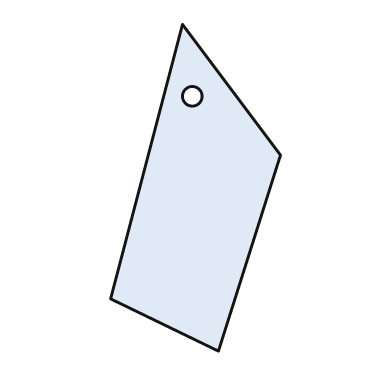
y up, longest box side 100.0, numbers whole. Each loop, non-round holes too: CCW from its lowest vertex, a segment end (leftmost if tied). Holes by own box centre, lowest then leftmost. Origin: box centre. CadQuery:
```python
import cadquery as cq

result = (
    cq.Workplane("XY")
    .moveTo(7.0, -50.0)
    .lineTo(26.0, 10.0)
    .lineTo(-4.0, 50.0)
    .lineTo(-26.0, -34.0)
    .close()
    .moveTo(-1.0, 28.0)
    .circle(3.0)
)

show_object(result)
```